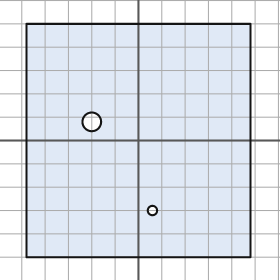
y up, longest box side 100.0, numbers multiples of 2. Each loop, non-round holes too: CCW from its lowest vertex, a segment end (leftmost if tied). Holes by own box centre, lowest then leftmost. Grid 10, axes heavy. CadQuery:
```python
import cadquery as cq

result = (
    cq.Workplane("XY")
    .moveTo(-48.0, -50.0)
    .lineTo(48.0, -50.0)
    .lineTo(48.0, 50.0)
    .lineTo(-48.0, 50.0)
    .close()
    .moveTo(6.0, -30.0)
    .circle(2.0)
    .moveTo(-20.0, 8.0)
    .circle(4.0)
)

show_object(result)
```